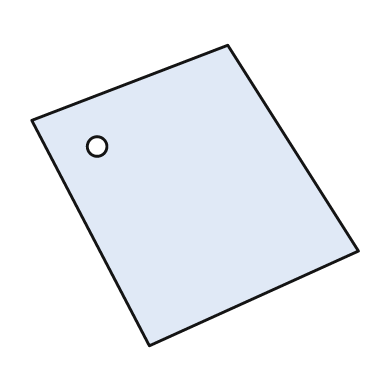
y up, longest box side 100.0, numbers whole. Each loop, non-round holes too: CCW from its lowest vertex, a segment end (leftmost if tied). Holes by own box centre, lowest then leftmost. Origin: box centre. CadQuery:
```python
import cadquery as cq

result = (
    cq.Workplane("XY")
    .moveTo(-14.0, -46.0)
    .lineTo(50.0, -17.0)
    .lineTo(10.0, 46.0)
    .lineTo(-50.0, 23.0)
    .close()
    .moveTo(-30.0, 15.0)
    .circle(3.0)
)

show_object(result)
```